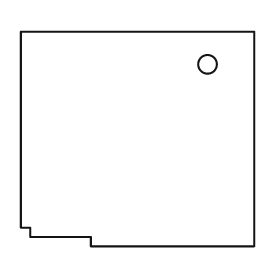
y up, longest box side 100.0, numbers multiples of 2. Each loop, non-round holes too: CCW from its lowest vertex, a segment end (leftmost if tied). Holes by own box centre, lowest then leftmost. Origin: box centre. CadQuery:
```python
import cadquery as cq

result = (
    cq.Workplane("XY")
    .moveTo(-20.0, -46.0)
    .lineTo(50.0, -46.0)
    .lineTo(50.0, 46.0)
    .lineTo(-50.0, 46.0)
    .lineTo(-50.0, -38.0)
    .lineTo(-46.0, -38.0)
    .lineTo(-46.0, -42.0)
    .lineTo(-20.0, -42.0)
    .close()
    .moveTo(30.0, 32.0)
    .circle(4.0)
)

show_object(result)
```